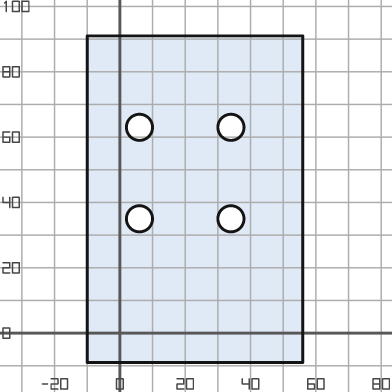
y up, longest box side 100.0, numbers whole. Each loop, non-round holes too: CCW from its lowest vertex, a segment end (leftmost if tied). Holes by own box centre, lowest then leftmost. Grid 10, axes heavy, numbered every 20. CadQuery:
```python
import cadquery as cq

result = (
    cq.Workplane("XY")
    .moveTo(-10.0, -9.0)
    .lineTo(56.0, -9.0)
    .lineTo(56.0, 91.0)
    .lineTo(-10.0, 91.0)
    .close()
    .moveTo(6.0, 35.0)
    .circle(4.0)
    .moveTo(34.0, 35.0)
    .circle(4.0)
    .moveTo(6.0, 63.0)
    .circle(4.0)
    .moveTo(34.0, 63.0)
    .circle(4.0)
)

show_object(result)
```